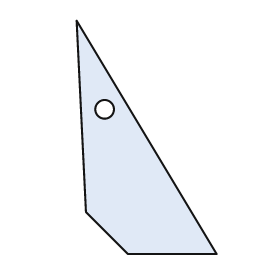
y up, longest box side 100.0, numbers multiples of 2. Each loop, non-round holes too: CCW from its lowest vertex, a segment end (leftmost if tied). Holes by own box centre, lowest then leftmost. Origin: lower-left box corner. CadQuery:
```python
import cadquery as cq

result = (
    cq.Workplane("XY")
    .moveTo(22.0, 0.0)
    .lineTo(60.0, 0.0)
    .lineTo(0.0, 100.0)
    .lineTo(4.0, 18.0)
    .close()
    .moveTo(12.0, 62.0)
    .circle(4.0)
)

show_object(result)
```